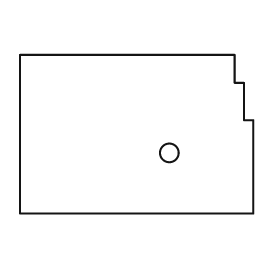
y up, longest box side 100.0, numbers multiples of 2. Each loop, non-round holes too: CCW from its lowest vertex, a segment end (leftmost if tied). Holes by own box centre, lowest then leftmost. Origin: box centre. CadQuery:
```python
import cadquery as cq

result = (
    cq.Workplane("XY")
    .moveTo(-50.0, -34.0)
    .lineTo(50.0, -34.0)
    .lineTo(50.0, 6.0)
    .lineTo(46.0, 6.0)
    .lineTo(46.0, 22.0)
    .lineTo(42.0, 22.0)
    .lineTo(42.0, 34.0)
    .lineTo(-50.0, 34.0)
    .close()
    .moveTo(14.0, -8.0)
    .circle(4.0)
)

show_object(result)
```